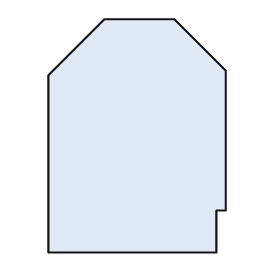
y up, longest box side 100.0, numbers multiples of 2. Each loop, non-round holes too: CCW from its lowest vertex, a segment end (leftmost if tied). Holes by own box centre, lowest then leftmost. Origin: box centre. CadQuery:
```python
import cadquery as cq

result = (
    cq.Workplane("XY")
    .moveTo(-38.0, -50.0)
    .lineTo(34.0, -50.0)
    .lineTo(34.0, -32.0)
    .lineTo(38.0, -32.0)
    .lineTo(38.0, 28.0)
    .lineTo(16.0, 50.0)
    .lineTo(-14.0, 50.0)
    .lineTo(-38.0, 26.0)
    .close()
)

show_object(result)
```